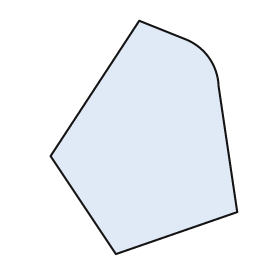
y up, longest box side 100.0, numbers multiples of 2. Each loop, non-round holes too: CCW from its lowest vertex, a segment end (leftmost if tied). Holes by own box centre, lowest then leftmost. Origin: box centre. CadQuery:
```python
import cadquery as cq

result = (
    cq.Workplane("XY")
    .moveTo(-12.0, -50.0)
    .lineTo(40.0, -32.0)
    .lineTo(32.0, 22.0)
    .threePointArc((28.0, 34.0), (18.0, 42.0))
    .lineTo(-2.0, 50.0)
    .lineTo(-40.0, -8.0)
    .close()
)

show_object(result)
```